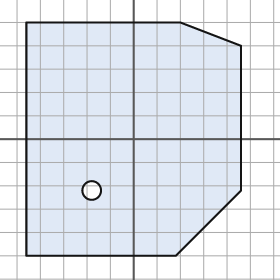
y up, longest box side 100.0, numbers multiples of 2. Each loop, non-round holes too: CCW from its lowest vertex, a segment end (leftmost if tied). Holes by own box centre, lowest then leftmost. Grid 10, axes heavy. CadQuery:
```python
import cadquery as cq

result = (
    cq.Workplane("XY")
    .moveTo(-46.0, -50.0)
    .lineTo(18.0, -50.0)
    .lineTo(46.0, -22.0)
    .lineTo(46.0, 40.0)
    .lineTo(20.0, 50.0)
    .lineTo(-46.0, 50.0)
    .close()
    .moveTo(-18.0, -22.0)
    .circle(4.0)
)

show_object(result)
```